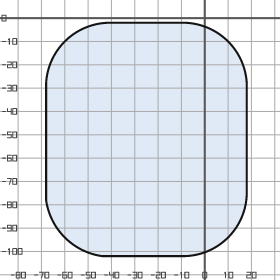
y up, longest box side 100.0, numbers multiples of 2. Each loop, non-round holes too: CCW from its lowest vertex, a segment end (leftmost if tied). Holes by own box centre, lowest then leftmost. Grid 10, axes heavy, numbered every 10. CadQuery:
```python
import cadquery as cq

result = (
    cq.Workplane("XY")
    .moveTo(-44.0, -102.0)
    .lineTo(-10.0, -102.0)
    .threePointArc((10.0, -94.0), (18.0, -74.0))
    .lineTo(18.0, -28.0)
    .threePointArc((10.0, -10.0), (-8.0, -2.0))
    .lineTo(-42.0, -2.0)
    .threePointArc((-60.0, -10.0), (-68.0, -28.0))
    .lineTo(-68.0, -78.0)
    .threePointArc((-60.0, -94.0), (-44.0, -102.0))
    .close()
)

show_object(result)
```